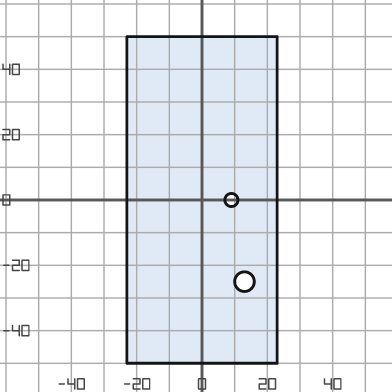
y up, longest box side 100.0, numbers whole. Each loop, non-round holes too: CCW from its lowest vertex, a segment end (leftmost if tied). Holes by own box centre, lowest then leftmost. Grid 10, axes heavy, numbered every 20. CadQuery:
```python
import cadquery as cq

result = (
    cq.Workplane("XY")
    .moveTo(-23.0, -50.0)
    .lineTo(23.0, -50.0)
    .lineTo(23.0, 50.0)
    .lineTo(-23.0, 50.0)
    .close()
    .moveTo(13.0, -25.0)
    .circle(3.0)
    .moveTo(9.0, 0.0)
    .circle(2.0)
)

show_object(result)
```